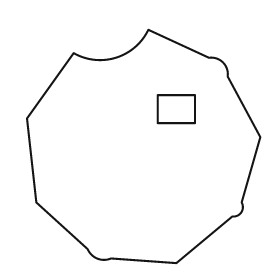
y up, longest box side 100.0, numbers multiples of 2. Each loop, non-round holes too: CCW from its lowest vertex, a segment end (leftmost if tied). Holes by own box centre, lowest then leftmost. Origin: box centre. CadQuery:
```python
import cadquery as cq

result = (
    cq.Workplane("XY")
    .moveTo(14.0, -50.0)
    .lineTo(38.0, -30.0)
    .threePointArc((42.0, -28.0), (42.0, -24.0))
    .lineTo(50.0, 4.0)
    .lineTo(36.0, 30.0)
    .threePointArc((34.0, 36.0), (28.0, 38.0))
    .lineTo(2.0, 50.0)
    .threePointArc((-12.0, 38.0), (-30.0, 40.0))
    .lineTo(-50.0, 12.0)
    .lineTo(-46.0, -24.0)
    .lineTo(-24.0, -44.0)
    .threePointArc((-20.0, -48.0), (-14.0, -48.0))
    .close()
    .moveTo(6.0, 10.0)
    .lineTo(22.0, 10.0)
    .lineTo(22.0, 22.0)
    .lineTo(6.0, 22.0)
    .close()
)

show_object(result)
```